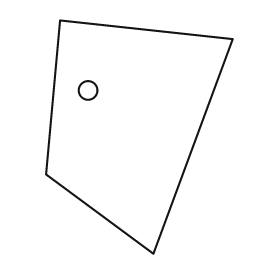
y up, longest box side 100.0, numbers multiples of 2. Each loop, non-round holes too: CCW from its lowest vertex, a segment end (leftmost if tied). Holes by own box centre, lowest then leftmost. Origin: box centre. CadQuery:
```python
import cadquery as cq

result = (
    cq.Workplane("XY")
    .moveTo(6.0, -50.0)
    .lineTo(40.0, 42.0)
    .lineTo(-34.0, 50.0)
    .lineTo(-40.0, -16.0)
    .close()
    .moveTo(-22.0, 20.0)
    .circle(4.0)
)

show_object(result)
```